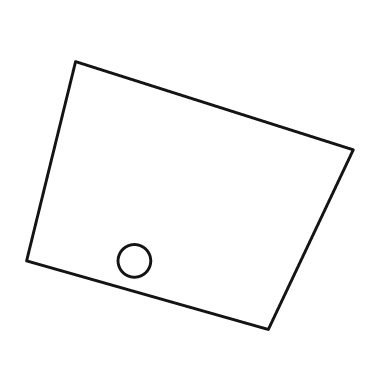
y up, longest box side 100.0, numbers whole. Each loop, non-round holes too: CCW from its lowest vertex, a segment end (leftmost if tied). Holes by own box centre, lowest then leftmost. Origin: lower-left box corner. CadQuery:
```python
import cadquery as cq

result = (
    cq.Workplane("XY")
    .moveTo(74.0, 0.0)
    .lineTo(100.0, 55.0)
    .lineTo(15.0, 82.0)
    .lineTo(0.0, 21.0)
    .close()
    .moveTo(33.0, 21.0)
    .circle(5.0)
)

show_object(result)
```